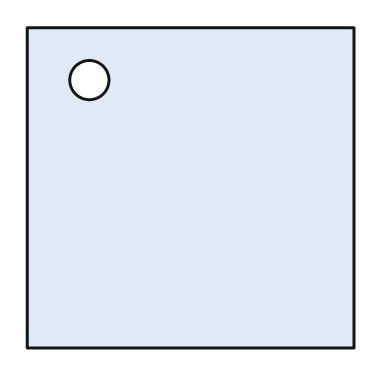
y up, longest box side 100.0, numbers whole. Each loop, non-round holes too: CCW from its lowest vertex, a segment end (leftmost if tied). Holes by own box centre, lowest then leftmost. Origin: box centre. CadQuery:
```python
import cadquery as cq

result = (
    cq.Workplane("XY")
    .moveTo(-50.0, -49.0)
    .lineTo(50.0, -49.0)
    .lineTo(50.0, 49.0)
    .lineTo(-50.0, 49.0)
    .close()
    .moveTo(-31.0, 33.0)
    .circle(6.0)
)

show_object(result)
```